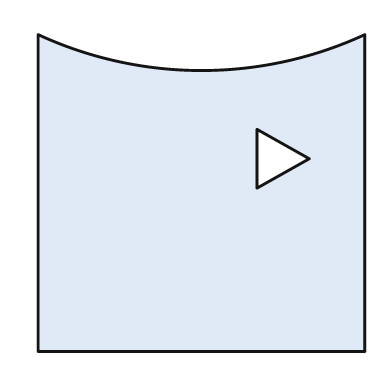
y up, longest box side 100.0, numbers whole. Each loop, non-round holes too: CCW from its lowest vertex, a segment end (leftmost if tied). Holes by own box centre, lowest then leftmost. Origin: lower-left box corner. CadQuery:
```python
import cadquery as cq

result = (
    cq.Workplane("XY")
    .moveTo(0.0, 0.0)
    .lineTo(100.0, 0.0)
    .lineTo(100.0, 97.0)
    .threePointArc((50.0, 86.0), (0.0, 97.0))
    .close()
    .moveTo(67.0, 50.0)
    .lineTo(83.0, 59.0)
    .lineTo(67.0, 68.0)
    .close()
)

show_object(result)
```